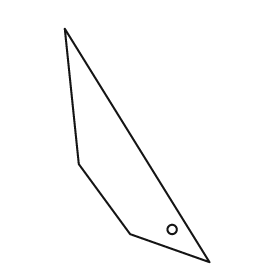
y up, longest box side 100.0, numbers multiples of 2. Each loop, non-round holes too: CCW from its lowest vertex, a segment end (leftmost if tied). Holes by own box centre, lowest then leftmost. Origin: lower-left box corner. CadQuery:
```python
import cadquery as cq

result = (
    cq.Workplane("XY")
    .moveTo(62.0, 0.0)
    .lineTo(0.0, 100.0)
    .lineTo(6.0, 42.0)
    .lineTo(28.0, 12.0)
    .close()
    .moveTo(46.0, 14.0)
    .circle(2.0)
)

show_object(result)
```